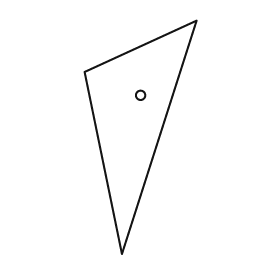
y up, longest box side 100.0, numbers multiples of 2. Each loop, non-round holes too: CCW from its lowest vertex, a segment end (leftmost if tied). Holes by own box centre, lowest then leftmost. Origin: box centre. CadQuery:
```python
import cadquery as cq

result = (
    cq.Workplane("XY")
    .moveTo(-8.0, -50.0)
    .lineTo(24.0, 50.0)
    .lineTo(-24.0, 28.0)
    .close()
    .moveTo(0.0, 18.0)
    .circle(2.0)
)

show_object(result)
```